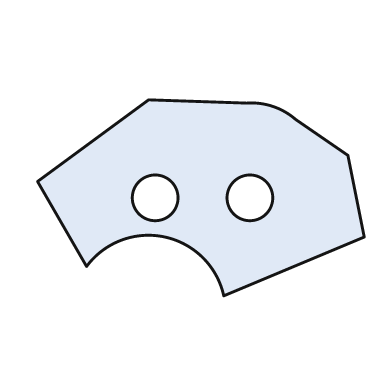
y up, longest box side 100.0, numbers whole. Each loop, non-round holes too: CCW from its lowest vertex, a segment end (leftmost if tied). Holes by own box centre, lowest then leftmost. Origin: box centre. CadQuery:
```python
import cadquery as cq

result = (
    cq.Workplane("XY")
    .moveTo(7.0, -30.0)
    .lineTo(50.0, -12.0)
    .lineTo(45.0, 13.0)
    .lineTo(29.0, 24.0)
    .threePointArc((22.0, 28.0), (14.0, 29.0))
    .lineTo(-16.0, 30.0)
    .lineTo(-50.0, 5.0)
    .lineTo(-35.0, -21.0)
    .threePointArc((-11.0, -12.0), (7.0, -30.0))
    .close()
    .moveTo(-14.0, 0.0)
    .circle(7.0)
    .moveTo(15.0, 0.0)
    .circle(7.0)
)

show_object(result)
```